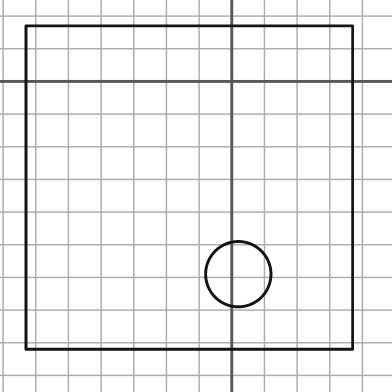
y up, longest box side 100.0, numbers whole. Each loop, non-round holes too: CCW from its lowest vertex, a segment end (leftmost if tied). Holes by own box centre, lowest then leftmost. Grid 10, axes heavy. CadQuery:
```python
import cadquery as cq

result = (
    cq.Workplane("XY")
    .moveTo(-63.0, -82.0)
    .lineTo(37.0, -82.0)
    .lineTo(37.0, 17.0)
    .lineTo(-63.0, 17.0)
    .close()
    .moveTo(2.0, -59.0)
    .circle(10.0)
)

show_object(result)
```